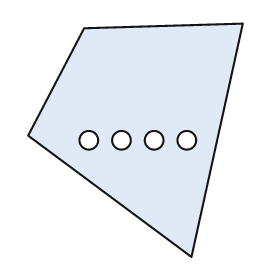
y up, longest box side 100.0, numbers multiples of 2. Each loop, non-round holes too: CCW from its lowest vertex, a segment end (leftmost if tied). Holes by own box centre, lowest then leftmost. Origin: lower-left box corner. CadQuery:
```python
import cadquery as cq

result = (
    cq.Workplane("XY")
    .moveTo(70.0, 0.0)
    .lineTo(92.0, 100.0)
    .lineTo(24.0, 98.0)
    .lineTo(0.0, 52.0)
    .close()
    .moveTo(26.0, 50.0)
    .circle(4.0)
    .moveTo(40.0, 50.0)
    .circle(4.0)
    .moveTo(54.0, 50.0)
    .circle(4.0)
    .moveTo(68.0, 50.0)
    .circle(4.0)
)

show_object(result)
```